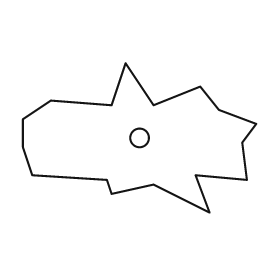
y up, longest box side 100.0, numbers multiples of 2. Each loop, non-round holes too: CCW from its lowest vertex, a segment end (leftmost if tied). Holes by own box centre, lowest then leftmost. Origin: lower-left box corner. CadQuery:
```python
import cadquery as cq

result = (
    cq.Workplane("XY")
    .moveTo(80.0, 0.0)
    .lineTo(74.0, 16.0)
    .lineTo(96.0, 14.0)
    .lineTo(94.0, 30.0)
    .lineTo(100.0, 38.0)
    .lineTo(84.0, 44.0)
    .lineTo(76.0, 54.0)
    .lineTo(56.0, 46.0)
    .lineTo(44.0, 64.0)
    .lineTo(38.0, 46.0)
    .lineTo(12.0, 48.0)
    .lineTo(0.0, 40.0)
    .lineTo(0.0, 28.0)
    .lineTo(4.0, 16.0)
    .lineTo(36.0, 14.0)
    .lineTo(38.0, 8.0)
    .lineTo(56.0, 12.0)
    .close()
    .moveTo(50.0, 32.0)
    .circle(4.0)
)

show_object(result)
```